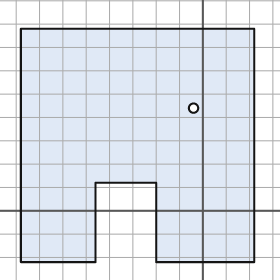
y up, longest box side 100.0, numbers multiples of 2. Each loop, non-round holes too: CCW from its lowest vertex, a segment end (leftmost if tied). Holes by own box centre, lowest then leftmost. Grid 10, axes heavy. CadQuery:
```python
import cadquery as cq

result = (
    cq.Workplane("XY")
    .moveTo(-78.0, -22.0)
    .lineTo(-46.0, -22.0)
    .lineTo(-46.0, 12.0)
    .lineTo(-20.0, 12.0)
    .lineTo(-20.0, -22.0)
    .lineTo(22.0, -22.0)
    .lineTo(22.0, 78.0)
    .lineTo(-78.0, 78.0)
    .close()
    .moveTo(-4.0, 44.0)
    .circle(2.0)
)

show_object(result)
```